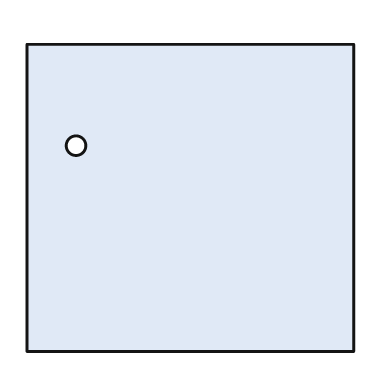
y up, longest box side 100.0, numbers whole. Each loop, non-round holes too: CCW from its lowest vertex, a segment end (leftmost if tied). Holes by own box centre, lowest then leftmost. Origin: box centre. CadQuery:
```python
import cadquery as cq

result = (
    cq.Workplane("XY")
    .moveTo(-50.0, -47.0)
    .lineTo(50.0, -47.0)
    .lineTo(50.0, 47.0)
    .lineTo(-50.0, 47.0)
    .close()
    .moveTo(-35.0, 16.0)
    .circle(3.0)
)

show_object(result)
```